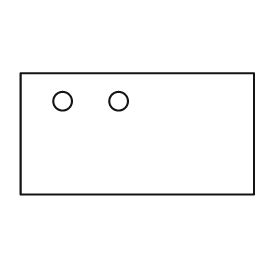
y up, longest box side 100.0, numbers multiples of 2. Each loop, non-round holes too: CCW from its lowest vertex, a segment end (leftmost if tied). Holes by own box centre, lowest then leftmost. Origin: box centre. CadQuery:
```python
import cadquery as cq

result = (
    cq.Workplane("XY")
    .moveTo(-50.0, -26.0)
    .lineTo(50.0, -26.0)
    .lineTo(50.0, 26.0)
    .lineTo(-50.0, 26.0)
    .close()
    .moveTo(-32.0, 14.0)
    .circle(4.0)
    .moveTo(-8.0, 14.0)
    .circle(4.0)
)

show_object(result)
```